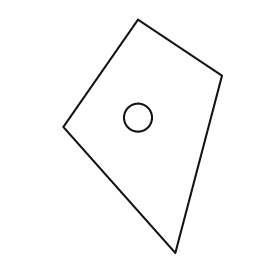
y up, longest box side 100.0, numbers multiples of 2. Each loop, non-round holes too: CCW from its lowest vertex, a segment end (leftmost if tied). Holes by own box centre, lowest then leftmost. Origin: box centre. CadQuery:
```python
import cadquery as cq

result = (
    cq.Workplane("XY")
    .moveTo(14.0, -50.0)
    .lineTo(34.0, 26.0)
    .lineTo(-2.0, 50.0)
    .lineTo(-34.0, 4.0)
    .close()
    .moveTo(-2.0, 8.0)
    .circle(6.0)
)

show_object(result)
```